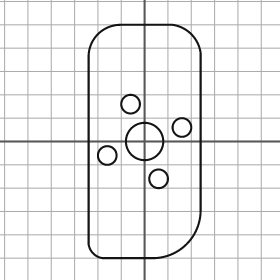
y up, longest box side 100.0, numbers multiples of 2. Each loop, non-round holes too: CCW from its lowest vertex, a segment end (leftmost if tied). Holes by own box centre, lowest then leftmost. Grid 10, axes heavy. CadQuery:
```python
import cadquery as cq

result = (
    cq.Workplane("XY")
    .moveTo(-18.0, -50.0)
    .lineTo(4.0, -50.0)
    .threePointArc((18.0, -44.0), (24.0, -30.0))
    .lineTo(24.0, 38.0)
    .threePointArc((20.0, 46.0), (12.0, 50.0))
    .lineTo(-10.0, 50.0)
    .threePointArc((-20.0, 46.0), (-24.0, 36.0))
    .lineTo(-24.0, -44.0)
    .threePointArc((-22.0, -48.0), (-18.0, -50.0))
    .close()
    .moveTo(6.0, -16.0)
    .circle(4.0)
    .moveTo(-16.0, -6.0)
    .circle(4.0)
    .moveTo(0.0, 0.0)
    .circle(8.0)
    .moveTo(16.0, 6.0)
    .circle(4.0)
    .moveTo(-6.0, 16.0)
    .circle(4.0)
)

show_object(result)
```